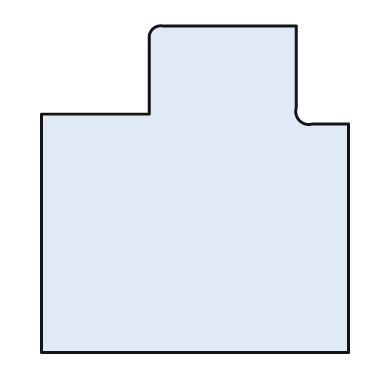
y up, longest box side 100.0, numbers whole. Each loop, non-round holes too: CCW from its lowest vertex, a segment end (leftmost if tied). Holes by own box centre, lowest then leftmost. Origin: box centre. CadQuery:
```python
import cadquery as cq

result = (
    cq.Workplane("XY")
    .moveTo(-47.0, -50.0)
    .lineTo(47.0, -50.0)
    .lineTo(47.0, 20.0)
    .lineTo(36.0, 20.0)
    .threePointArc((32.0, 21.0), (31.0, 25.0))
    .lineTo(31.0, 50.0)
    .lineTo(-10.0, 50.0)
    .threePointArc((-13.0, 49.0), (-14.0, 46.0))
    .lineTo(-14.0, 23.0)
    .lineTo(-47.0, 23.0)
    .close()
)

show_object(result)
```